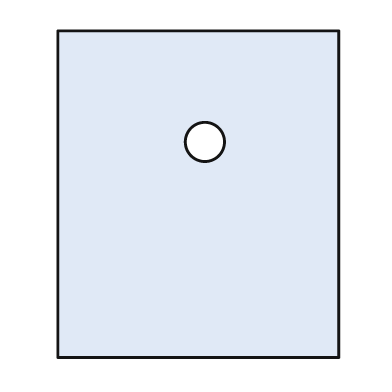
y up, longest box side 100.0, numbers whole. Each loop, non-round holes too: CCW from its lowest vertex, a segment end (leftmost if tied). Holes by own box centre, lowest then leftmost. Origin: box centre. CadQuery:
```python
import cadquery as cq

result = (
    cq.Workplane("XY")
    .moveTo(-43.0, -50.0)
    .lineTo(43.0, -50.0)
    .lineTo(43.0, 50.0)
    .lineTo(-43.0, 50.0)
    .close()
    .moveTo(2.0, 16.0)
    .circle(6.0)
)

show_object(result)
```